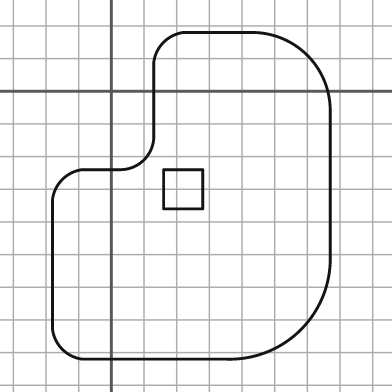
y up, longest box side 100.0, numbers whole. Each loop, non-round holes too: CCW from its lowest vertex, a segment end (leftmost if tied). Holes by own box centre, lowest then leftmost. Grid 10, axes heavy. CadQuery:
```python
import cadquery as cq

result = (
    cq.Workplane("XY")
    .moveTo(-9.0, -82.0)
    .lineTo(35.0, -82.0)
    .threePointArc((58.0, -73.0), (67.0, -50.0))
    .lineTo(67.0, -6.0)
    .threePointArc((60.0, 11.0), (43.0, 18.0))
    .lineTo(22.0, 18.0)
    .threePointArc((16.0, 15.0), (13.0, 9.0))
    .lineTo(13.0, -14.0)
    .threePointArc((10.0, -21.0), (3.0, -24.0))
    .lineTo(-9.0, -24.0)
    .threePointArc((-15.0, -27.0), (-18.0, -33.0))
    .lineTo(-18.0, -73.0)
    .threePointArc((-15.0, -79.0), (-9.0, -82.0))
    .close()
    .moveTo(16.0, -36.0)
    .lineTo(28.0, -36.0)
    .lineTo(28.0, -24.0)
    .lineTo(16.0, -24.0)
    .close()
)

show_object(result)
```